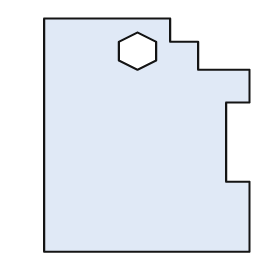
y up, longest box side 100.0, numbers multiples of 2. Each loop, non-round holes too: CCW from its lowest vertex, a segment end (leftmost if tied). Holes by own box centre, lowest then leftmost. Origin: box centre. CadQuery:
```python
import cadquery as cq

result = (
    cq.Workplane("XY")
    .moveTo(-44.0, -50.0)
    .lineTo(44.0, -50.0)
    .lineTo(44.0, -20.0)
    .lineTo(34.0, -20.0)
    .lineTo(34.0, 14.0)
    .lineTo(44.0, 14.0)
    .lineTo(44.0, 28.0)
    .lineTo(22.0, 28.0)
    .lineTo(22.0, 40.0)
    .lineTo(10.0, 40.0)
    .lineTo(10.0, 50.0)
    .lineTo(-44.0, 50.0)
    .close()
    .moveTo(-4.0, 28.0)
    .lineTo(4.0, 32.0)
    .lineTo(4.0, 40.0)
    .lineTo(-4.0, 44.0)
    .lineTo(-12.0, 40.0)
    .lineTo(-12.0, 32.0)
    .close()
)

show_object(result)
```